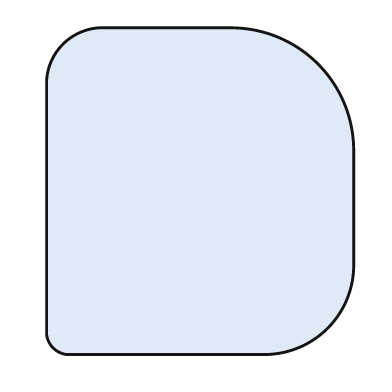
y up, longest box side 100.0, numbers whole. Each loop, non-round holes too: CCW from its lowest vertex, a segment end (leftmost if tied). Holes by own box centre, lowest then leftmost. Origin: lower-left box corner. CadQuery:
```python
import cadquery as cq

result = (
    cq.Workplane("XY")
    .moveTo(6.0, 0.0)
    .lineTo(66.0, 0.0)
    .threePointArc((86.0, 8.0), (94.0, 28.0))
    .lineTo(94.0, 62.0)
    .threePointArc((83.0, 89.0), (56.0, 100.0))
    .lineTo(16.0, 100.0)
    .threePointArc((5.0, 95.0), (0.0, 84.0))
    .lineTo(0.0, 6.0)
    .threePointArc((2.0, 2.0), (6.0, 0.0))
    .close()
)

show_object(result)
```